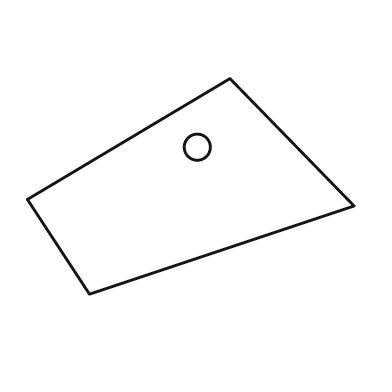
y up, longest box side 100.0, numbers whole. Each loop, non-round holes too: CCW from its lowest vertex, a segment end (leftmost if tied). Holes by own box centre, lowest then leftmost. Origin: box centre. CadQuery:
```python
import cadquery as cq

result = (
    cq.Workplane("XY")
    .moveTo(-31.0, -33.0)
    .lineTo(50.0, -6.0)
    .lineTo(12.0, 33.0)
    .lineTo(-50.0, -4.0)
    .close()
    .moveTo(2.0, 12.0)
    .circle(4.0)
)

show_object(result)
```